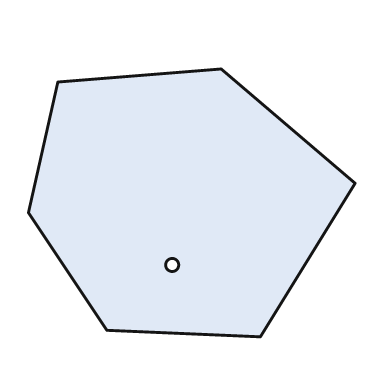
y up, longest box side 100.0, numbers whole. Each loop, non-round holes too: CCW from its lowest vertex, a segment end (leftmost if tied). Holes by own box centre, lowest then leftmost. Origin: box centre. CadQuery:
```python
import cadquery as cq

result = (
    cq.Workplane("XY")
    .moveTo(21.0, -41.0)
    .lineTo(50.0, 6.0)
    .lineTo(9.0, 41.0)
    .lineTo(-41.0, 37.0)
    .lineTo(-50.0, -3.0)
    .lineTo(-26.0, -39.0)
    .close()
    .moveTo(-6.0, -19.0)
    .circle(2.0)
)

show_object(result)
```